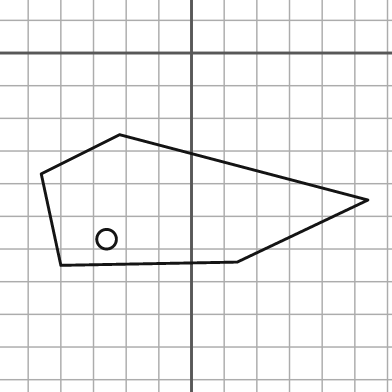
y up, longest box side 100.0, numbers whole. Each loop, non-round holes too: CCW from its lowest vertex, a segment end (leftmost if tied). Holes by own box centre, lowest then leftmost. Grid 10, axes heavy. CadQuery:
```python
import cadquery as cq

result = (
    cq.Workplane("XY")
    .moveTo(-40.0, -65.0)
    .lineTo(14.0, -64.0)
    .lineTo(54.0, -45.0)
    .lineTo(-22.0, -25.0)
    .lineTo(-46.0, -37.0)
    .close()
    .moveTo(-26.0, -57.0)
    .circle(3.0)
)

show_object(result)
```